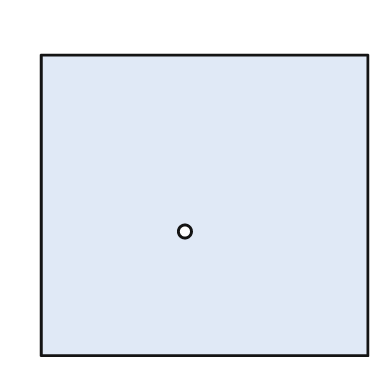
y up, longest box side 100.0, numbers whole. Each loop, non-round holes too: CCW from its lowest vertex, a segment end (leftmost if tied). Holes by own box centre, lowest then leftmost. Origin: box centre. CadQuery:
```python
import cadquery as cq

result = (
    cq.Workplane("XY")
    .moveTo(-50.0, -46.0)
    .lineTo(50.0, -46.0)
    .lineTo(50.0, 46.0)
    .lineTo(-50.0, 46.0)
    .close()
    .moveTo(-6.0, -8.0)
    .circle(2.0)
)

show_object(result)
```